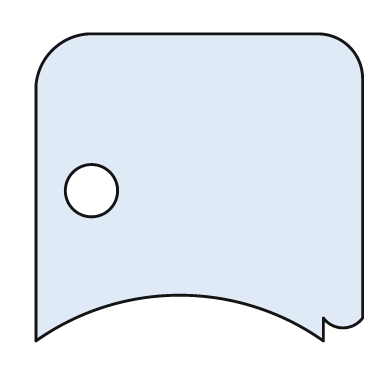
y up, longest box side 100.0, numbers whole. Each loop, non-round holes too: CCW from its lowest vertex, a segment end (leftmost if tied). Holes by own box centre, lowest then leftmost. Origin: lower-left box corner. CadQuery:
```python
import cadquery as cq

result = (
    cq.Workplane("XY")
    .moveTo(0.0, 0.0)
    .threePointArc((44.0, 14.0), (88.0, 0.0))
    .lineTo(88.0, 7.0)
    .threePointArc((94.0, 4.0), (100.0, 7.0))
    .lineTo(100.0, 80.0)
    .threePointArc((96.0, 90.0), (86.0, 94.0))
    .lineTo(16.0, 94.0)
    .threePointArc((5.0, 89.0), (0.0, 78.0))
    .close()
    .moveTo(17.0, 46.0)
    .circle(8.0)
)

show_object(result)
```